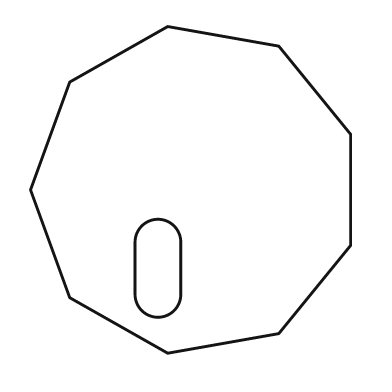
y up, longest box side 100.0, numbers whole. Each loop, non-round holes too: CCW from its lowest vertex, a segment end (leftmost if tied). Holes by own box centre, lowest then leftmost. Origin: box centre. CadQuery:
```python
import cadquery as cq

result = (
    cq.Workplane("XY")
    .moveTo(-7.0, -50.0)
    .lineTo(27.0, -44.0)
    .lineTo(49.0, -17.0)
    .lineTo(49.0, 17.0)
    .lineTo(27.0, 44.0)
    .lineTo(-7.0, 50.0)
    .lineTo(-37.0, 33.0)
    .lineTo(-49.0, 0.0)
    .lineTo(-37.0, -33.0)
    .close()
    .moveTo(-17.0, -32.0)
    .threePointArc((-10.0, -39.0), (-3.0, -32.0))
    .lineTo(-3.0, -16.0)
    .threePointArc((-10.0, -9.0), (-17.0, -16.0))
    .close()
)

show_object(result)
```